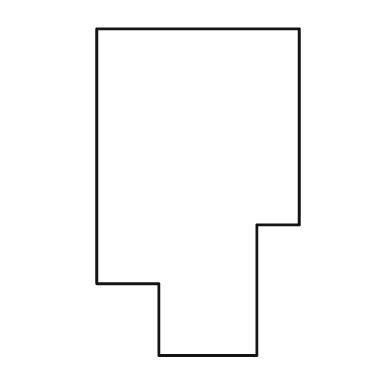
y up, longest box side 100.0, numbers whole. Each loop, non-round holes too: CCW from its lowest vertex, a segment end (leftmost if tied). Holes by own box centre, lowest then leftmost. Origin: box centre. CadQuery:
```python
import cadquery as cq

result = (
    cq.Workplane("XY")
    .moveTo(-12.0, -50.0)
    .lineTo(18.0, -50.0)
    .lineTo(18.0, -10.0)
    .lineTo(31.0, -10.0)
    .lineTo(31.0, 50.0)
    .lineTo(-31.0, 50.0)
    .lineTo(-31.0, -28.0)
    .lineTo(-12.0, -28.0)
    .close()
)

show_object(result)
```